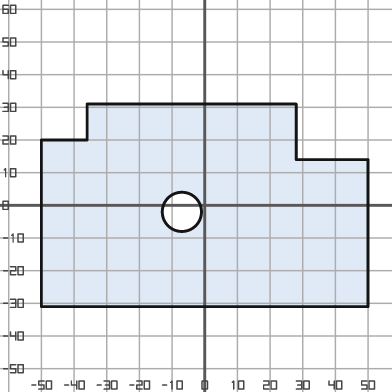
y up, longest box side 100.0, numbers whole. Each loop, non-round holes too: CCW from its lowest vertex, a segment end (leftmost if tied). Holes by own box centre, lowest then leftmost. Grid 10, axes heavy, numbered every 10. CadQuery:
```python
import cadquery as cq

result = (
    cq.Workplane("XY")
    .moveTo(-50.0, -31.0)
    .lineTo(50.0, -31.0)
    .lineTo(50.0, 14.0)
    .lineTo(28.0, 14.0)
    .lineTo(28.0, 31.0)
    .lineTo(-36.0, 31.0)
    .lineTo(-36.0, 20.0)
    .lineTo(-50.0, 20.0)
    .close()
    .moveTo(-7.0, -2.0)
    .circle(6.0)
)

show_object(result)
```